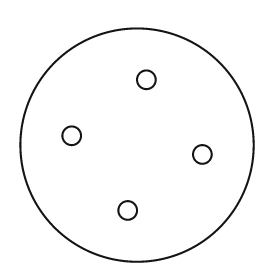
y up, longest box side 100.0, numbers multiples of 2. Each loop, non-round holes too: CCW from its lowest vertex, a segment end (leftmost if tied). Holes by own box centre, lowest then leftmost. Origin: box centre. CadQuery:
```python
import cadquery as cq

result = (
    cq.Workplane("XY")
    .moveTo(0.0, 0.0)
    .circle(50.0)
    .moveTo(-4.0, -28.0)
    .circle(4.0)
    .moveTo(28.0, -4.0)
    .circle(4.0)
    .moveTo(-28.0, 4.0)
    .circle(4.0)
    .moveTo(4.0, 28.0)
    .circle(4.0)
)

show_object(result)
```